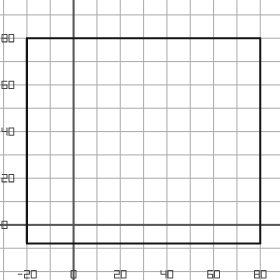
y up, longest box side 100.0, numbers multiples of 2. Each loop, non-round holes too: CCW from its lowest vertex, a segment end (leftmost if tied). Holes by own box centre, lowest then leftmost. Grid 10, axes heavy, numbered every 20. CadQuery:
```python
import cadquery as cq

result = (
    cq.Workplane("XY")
    .moveTo(-20.0, -8.0)
    .lineTo(80.0, -8.0)
    .lineTo(80.0, 80.0)
    .lineTo(-20.0, 80.0)
    .close()
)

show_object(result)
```